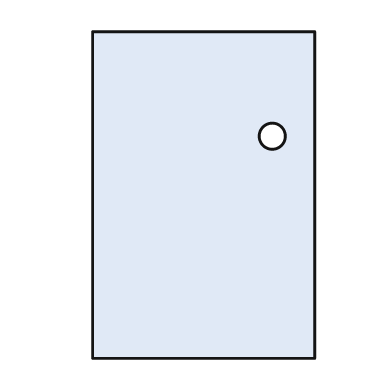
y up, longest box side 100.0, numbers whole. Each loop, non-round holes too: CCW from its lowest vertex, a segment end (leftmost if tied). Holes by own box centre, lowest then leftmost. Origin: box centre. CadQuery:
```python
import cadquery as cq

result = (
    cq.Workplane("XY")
    .moveTo(-34.0, -50.0)
    .lineTo(34.0, -50.0)
    .lineTo(34.0, 50.0)
    .lineTo(-34.0, 50.0)
    .close()
    .moveTo(21.0, 18.0)
    .circle(4.0)
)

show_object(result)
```